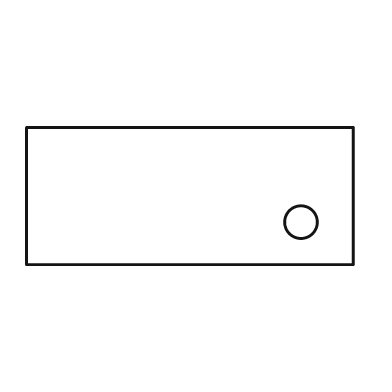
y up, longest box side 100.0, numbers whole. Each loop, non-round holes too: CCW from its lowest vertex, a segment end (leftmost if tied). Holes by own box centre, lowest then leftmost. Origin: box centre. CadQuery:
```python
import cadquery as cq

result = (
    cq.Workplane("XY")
    .moveTo(-50.0, -21.0)
    .lineTo(50.0, -21.0)
    .lineTo(50.0, 21.0)
    .lineTo(-50.0, 21.0)
    .close()
    .moveTo(34.0, -8.0)
    .circle(5.0)
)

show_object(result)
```